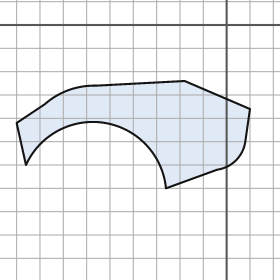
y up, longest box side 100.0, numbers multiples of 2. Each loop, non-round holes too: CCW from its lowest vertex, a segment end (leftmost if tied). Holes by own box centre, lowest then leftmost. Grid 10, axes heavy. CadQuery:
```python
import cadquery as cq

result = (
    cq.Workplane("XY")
    .moveTo(-26.0, -70.0)
    .lineTo(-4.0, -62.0)
    .threePointArc((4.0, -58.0), (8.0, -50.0))
    .lineTo(10.0, -36.0)
    .lineTo(-18.0, -24.0)
    .lineTo(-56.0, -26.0)
    .threePointArc((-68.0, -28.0), (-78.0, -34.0))
    .lineTo(-90.0, -42.0)
    .lineTo(-86.0, -60.0)
    .threePointArc((-52.0, -42.0), (-26.0, -70.0))
    .close()
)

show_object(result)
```